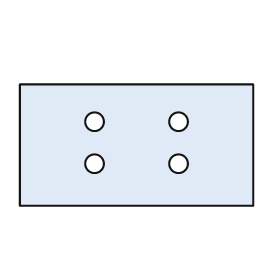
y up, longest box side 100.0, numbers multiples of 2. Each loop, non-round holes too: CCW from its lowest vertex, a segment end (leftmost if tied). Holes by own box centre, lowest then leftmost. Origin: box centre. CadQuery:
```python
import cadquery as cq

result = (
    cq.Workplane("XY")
    .moveTo(-50.0, -26.0)
    .lineTo(50.0, -26.0)
    .lineTo(50.0, 26.0)
    .lineTo(-50.0, 26.0)
    .close()
    .moveTo(-18.0, -8.0)
    .circle(4.0)
    .moveTo(18.0, -8.0)
    .circle(4.0)
    .moveTo(-18.0, 10.0)
    .circle(4.0)
    .moveTo(18.0, 10.0)
    .circle(4.0)
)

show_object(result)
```